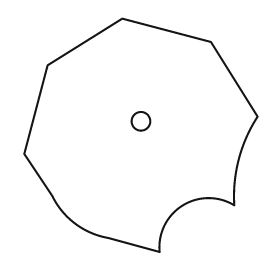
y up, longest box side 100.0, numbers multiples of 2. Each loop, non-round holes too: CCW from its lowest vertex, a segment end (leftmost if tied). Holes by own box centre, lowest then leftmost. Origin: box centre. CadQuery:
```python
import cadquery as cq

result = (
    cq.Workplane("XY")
    .moveTo(8.0, -50.0)
    .threePointArc((18.0, -30.0), (40.0, -30.0))
    .threePointArc((42.0, -10.0), (50.0, 8.0))
    .lineTo(30.0, 40.0)
    .lineTo(-8.0, 50.0)
    .lineTo(-40.0, 30.0)
    .lineTo(-50.0, -8.0)
    .lineTo(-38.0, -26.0)
    .threePointArc((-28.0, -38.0), (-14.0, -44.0))
    .close()
    .moveTo(0.0, 6.0)
    .circle(4.0)
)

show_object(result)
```